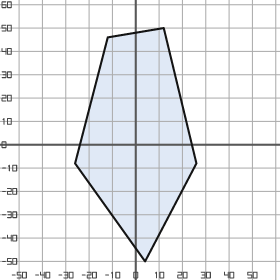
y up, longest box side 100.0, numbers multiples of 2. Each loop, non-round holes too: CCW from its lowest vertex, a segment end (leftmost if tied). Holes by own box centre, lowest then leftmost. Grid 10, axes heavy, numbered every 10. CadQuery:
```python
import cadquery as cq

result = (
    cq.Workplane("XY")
    .moveTo(4.0, -50.0)
    .lineTo(26.0, -8.0)
    .lineTo(12.0, 50.0)
    .lineTo(-12.0, 46.0)
    .lineTo(-26.0, -8.0)
    .close()
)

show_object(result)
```